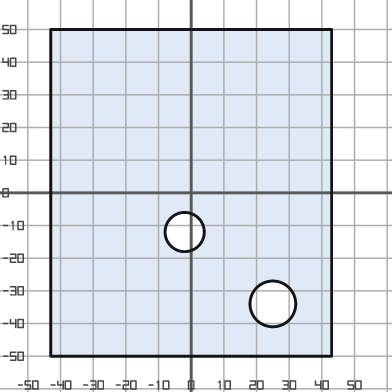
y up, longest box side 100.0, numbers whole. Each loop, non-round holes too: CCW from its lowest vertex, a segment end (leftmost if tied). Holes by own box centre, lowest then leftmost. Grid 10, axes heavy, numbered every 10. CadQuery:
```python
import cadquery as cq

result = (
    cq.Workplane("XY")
    .moveTo(-43.0, -50.0)
    .lineTo(43.0, -50.0)
    .lineTo(43.0, 50.0)
    .lineTo(-43.0, 50.0)
    .close()
    .moveTo(25.0, -34.0)
    .circle(7.0)
    .moveTo(-2.0, -12.0)
    .circle(6.0)
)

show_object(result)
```